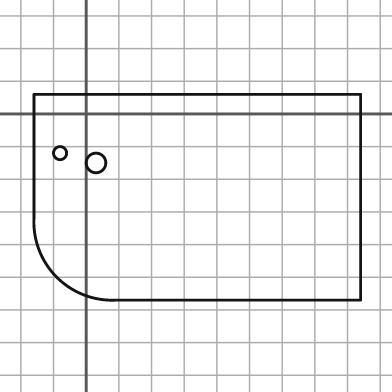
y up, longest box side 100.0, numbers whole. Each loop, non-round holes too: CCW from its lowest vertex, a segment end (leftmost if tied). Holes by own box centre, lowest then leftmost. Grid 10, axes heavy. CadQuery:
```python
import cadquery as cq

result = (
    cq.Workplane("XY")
    .moveTo(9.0, -57.0)
    .lineTo(84.0, -57.0)
    .lineTo(84.0, 6.0)
    .lineTo(-16.0, 6.0)
    .lineTo(-16.0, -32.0)
    .threePointArc((-9.0, -50.0), (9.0, -57.0))
    .close()
    .moveTo(3.0, -15.0)
    .circle(3.0)
    .moveTo(-8.0, -12.0)
    .circle(2.0)
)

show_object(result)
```